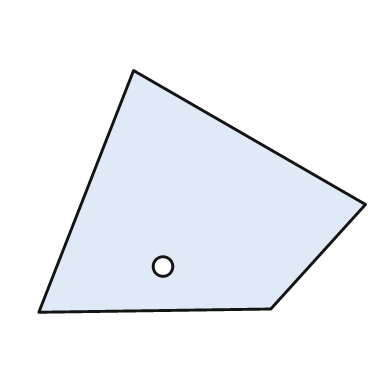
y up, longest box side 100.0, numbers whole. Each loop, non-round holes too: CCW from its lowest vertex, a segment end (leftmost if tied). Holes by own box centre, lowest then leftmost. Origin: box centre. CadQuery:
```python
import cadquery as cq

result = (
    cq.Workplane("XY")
    .moveTo(-50.0, -37.0)
    .lineTo(21.0, -36.0)
    .lineTo(50.0, -4.0)
    .lineTo(-21.0, 37.0)
    .close()
    .moveTo(-12.0, -23.0)
    .circle(3.0)
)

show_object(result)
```